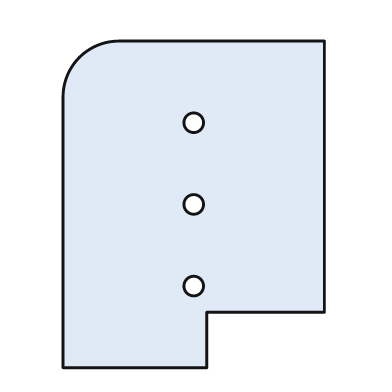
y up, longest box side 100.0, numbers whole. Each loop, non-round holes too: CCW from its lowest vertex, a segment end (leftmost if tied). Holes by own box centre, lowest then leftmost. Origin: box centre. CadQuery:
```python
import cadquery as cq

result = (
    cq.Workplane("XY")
    .moveTo(-40.0, -50.0)
    .lineTo(4.0, -50.0)
    .lineTo(4.0, -33.0)
    .lineTo(40.0, -33.0)
    .lineTo(40.0, 50.0)
    .lineTo(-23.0, 50.0)
    .threePointArc((-35.0, 45.0), (-40.0, 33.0))
    .close()
    .moveTo(0.0, -25.0)
    .circle(3.0)
    .moveTo(0.0, 0.0)
    .circle(3.0)
    .moveTo(0.0, 25.0)
    .circle(3.0)
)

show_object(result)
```